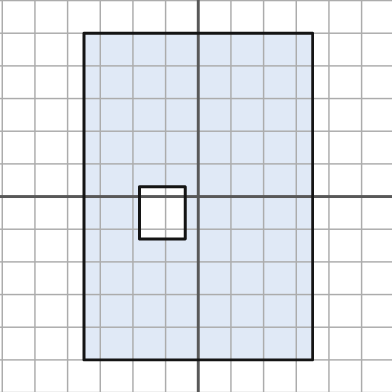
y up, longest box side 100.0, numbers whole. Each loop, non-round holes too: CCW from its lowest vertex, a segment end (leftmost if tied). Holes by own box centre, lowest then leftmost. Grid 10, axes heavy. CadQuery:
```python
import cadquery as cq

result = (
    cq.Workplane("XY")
    .moveTo(-35.0, -50.0)
    .lineTo(35.0, -50.0)
    .lineTo(35.0, 50.0)
    .lineTo(-35.0, 50.0)
    .close()
    .moveTo(-18.0, -13.0)
    .lineTo(-4.0, -13.0)
    .lineTo(-4.0, 3.0)
    .lineTo(-18.0, 3.0)
    .close()
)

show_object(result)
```